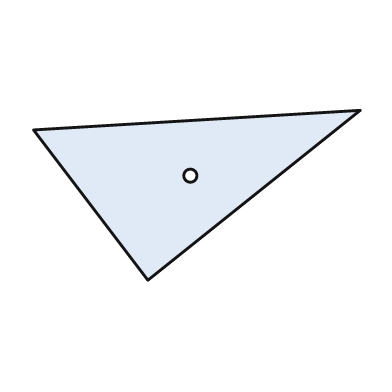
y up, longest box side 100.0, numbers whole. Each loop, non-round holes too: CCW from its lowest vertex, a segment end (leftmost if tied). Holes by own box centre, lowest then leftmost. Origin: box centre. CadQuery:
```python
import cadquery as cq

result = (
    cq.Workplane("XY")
    .moveTo(-15.0, -26.0)
    .lineTo(50.0, 26.0)
    .lineTo(-50.0, 20.0)
    .close()
    .moveTo(-2.0, 6.0)
    .circle(2.0)
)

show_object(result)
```